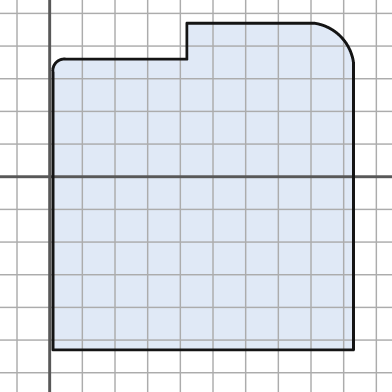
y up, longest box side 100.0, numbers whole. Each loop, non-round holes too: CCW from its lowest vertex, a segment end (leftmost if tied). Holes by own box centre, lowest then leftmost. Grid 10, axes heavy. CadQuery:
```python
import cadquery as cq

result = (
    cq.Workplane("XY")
    .moveTo(1.0, -53.0)
    .lineTo(93.0, -53.0)
    .lineTo(93.0, 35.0)
    .threePointArc((89.0, 43.0), (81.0, 47.0))
    .lineTo(42.0, 47.0)
    .lineTo(42.0, 36.0)
    .lineTo(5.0, 36.0)
    .threePointArc((2.0, 35.0), (1.0, 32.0))
    .close()
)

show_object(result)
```